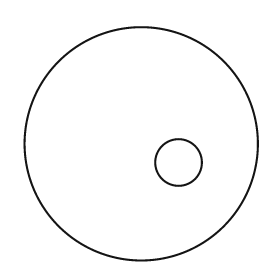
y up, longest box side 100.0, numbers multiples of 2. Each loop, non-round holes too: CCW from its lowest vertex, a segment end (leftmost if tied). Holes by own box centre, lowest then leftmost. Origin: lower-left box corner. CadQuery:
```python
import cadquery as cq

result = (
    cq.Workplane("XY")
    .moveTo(50.0, 50.0)
    .circle(50.0)
    .moveTo(66.0, 42.0)
    .circle(10.0)
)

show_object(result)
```